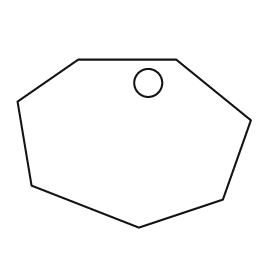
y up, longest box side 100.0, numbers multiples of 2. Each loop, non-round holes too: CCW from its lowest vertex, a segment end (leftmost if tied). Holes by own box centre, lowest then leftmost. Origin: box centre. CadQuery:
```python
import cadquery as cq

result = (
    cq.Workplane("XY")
    .moveTo(2.0, -36.0)
    .lineTo(38.0, -24.0)
    .lineTo(50.0, 10.0)
    .lineTo(18.0, 36.0)
    .lineTo(-24.0, 36.0)
    .lineTo(-50.0, 18.0)
    .lineTo(-44.0, -18.0)
    .close()
    .moveTo(6.0, 26.0)
    .circle(6.0)
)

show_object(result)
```